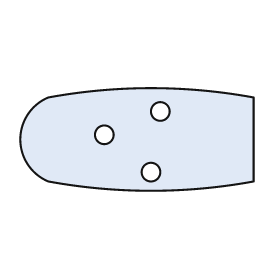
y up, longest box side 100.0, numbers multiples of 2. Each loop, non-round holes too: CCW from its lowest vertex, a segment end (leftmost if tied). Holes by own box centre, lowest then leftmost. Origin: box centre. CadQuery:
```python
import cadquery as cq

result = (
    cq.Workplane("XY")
    .moveTo(-38.0, -18.0)
    .threePointArc((6.0, -22.0), (50.0, -18.0))
    .lineTo(50.0, 18.0)
    .threePointArc((6.0, 22.0), (-38.0, 18.0))
    .threePointArc((-50.0, 0.0), (-38.0, -18.0))
    .close()
    .moveTo(6.0, -14.0)
    .circle(4.0)
    .moveTo(-14.0, 2.0)
    .circle(4.0)
    .moveTo(10.0, 12.0)
    .circle(4.0)
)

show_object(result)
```